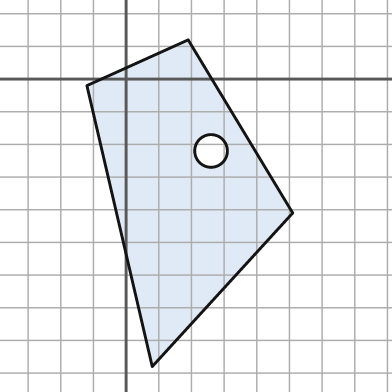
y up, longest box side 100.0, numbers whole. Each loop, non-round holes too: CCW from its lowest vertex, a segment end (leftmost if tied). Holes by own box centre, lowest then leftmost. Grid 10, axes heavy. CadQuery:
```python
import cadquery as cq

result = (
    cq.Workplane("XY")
    .moveTo(8.0, -88.0)
    .lineTo(51.0, -41.0)
    .lineTo(19.0, 12.0)
    .lineTo(-12.0, -2.0)
    .close()
    .moveTo(26.0, -22.0)
    .circle(5.0)
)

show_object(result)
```